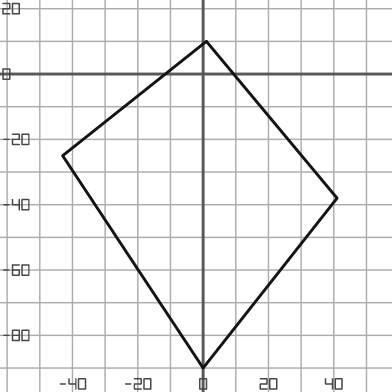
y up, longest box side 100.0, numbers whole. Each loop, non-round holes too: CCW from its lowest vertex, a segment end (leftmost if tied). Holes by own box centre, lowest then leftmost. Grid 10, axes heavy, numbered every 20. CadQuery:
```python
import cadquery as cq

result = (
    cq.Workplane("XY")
    .moveTo(0.0, -90.0)
    .lineTo(41.0, -38.0)
    .lineTo(1.0, 10.0)
    .lineTo(-43.0, -25.0)
    .close()
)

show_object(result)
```